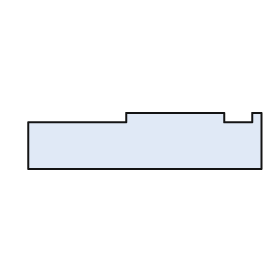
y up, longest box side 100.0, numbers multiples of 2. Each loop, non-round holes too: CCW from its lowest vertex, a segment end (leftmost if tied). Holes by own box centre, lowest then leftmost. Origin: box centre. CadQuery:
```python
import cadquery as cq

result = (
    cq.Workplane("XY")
    .moveTo(-50.0, -12.0)
    .lineTo(50.0, -12.0)
    .lineTo(50.0, 12.0)
    .lineTo(46.0, 12.0)
    .lineTo(46.0, 8.0)
    .lineTo(34.0, 8.0)
    .lineTo(34.0, 12.0)
    .lineTo(-8.0, 12.0)
    .lineTo(-8.0, 8.0)
    .lineTo(-50.0, 8.0)
    .close()
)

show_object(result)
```